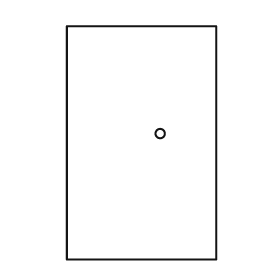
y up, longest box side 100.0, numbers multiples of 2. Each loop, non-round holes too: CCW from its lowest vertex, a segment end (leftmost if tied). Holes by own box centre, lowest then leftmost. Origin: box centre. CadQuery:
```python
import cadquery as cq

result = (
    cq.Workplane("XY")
    .moveTo(-32.0, -50.0)
    .lineTo(32.0, -50.0)
    .lineTo(32.0, 50.0)
    .lineTo(-32.0, 50.0)
    .close()
    .moveTo(8.0, 4.0)
    .circle(2.0)
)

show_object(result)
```